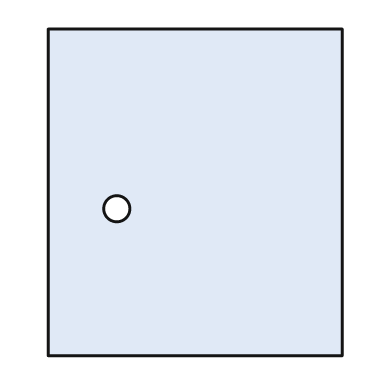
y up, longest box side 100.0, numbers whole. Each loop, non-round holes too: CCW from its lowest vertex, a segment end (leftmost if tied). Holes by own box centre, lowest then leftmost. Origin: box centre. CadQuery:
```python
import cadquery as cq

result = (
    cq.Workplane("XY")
    .moveTo(-45.0, -50.0)
    .lineTo(45.0, -50.0)
    .lineTo(45.0, 50.0)
    .lineTo(-45.0, 50.0)
    .close()
    .moveTo(-24.0, -5.0)
    .circle(4.0)
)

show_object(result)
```